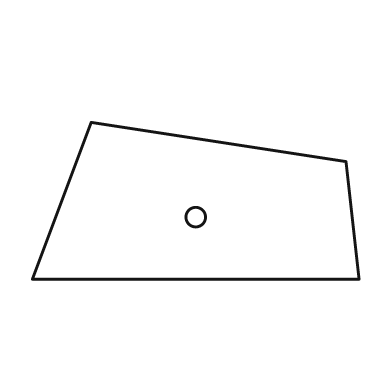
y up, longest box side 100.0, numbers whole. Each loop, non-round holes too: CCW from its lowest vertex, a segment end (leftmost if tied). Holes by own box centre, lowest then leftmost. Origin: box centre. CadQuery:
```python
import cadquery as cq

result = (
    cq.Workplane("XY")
    .moveTo(-50.0, -24.0)
    .lineTo(50.0, -24.0)
    .lineTo(46.0, 12.0)
    .lineTo(-32.0, 24.0)
    .close()
    .moveTo(0.0, -5.0)
    .circle(3.0)
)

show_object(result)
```